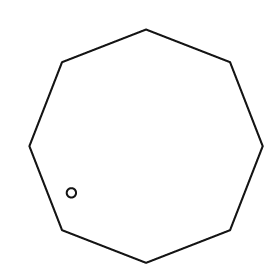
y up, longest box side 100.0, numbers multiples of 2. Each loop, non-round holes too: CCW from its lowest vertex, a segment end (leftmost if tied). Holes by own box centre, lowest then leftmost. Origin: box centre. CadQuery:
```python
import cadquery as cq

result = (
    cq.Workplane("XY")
    .moveTo(0.0, -50.0)
    .lineTo(36.0, -36.0)
    .lineTo(50.0, 0.0)
    .lineTo(36.0, 36.0)
    .lineTo(0.0, 50.0)
    .lineTo(-36.0, 36.0)
    .lineTo(-50.0, 0.0)
    .lineTo(-36.0, -36.0)
    .close()
    .moveTo(-32.0, -20.0)
    .circle(2.0)
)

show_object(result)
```